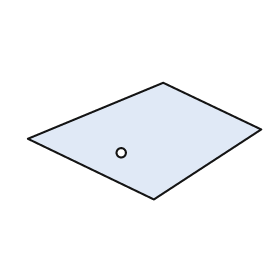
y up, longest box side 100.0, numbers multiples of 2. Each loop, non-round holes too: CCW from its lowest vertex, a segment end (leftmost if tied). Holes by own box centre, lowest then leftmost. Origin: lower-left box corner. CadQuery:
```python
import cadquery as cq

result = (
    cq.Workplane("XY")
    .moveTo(54.0, 0.0)
    .lineTo(100.0, 30.0)
    .lineTo(58.0, 50.0)
    .lineTo(0.0, 26.0)
    .close()
    .moveTo(40.0, 20.0)
    .circle(2.0)
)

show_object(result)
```